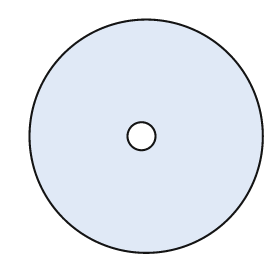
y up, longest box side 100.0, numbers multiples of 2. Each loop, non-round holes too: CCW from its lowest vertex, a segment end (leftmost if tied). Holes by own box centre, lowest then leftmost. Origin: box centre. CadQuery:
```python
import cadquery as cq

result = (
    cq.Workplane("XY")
    .moveTo(0.0, 0.0)
    .circle(50.0)
    .moveTo(-2.0, 0.0)
    .circle(6.0)
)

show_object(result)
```